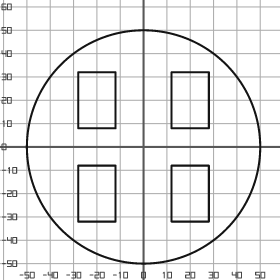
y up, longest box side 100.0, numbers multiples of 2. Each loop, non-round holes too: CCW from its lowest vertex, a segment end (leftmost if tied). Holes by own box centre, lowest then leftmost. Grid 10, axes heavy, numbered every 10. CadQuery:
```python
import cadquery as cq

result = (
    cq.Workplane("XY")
    .moveTo(0.0, 0.0)
    .circle(50.0)
    .moveTo(-28.0, -32.0)
    .lineTo(-12.0, -32.0)
    .lineTo(-12.0, -8.0)
    .lineTo(-28.0, -8.0)
    .close()
    .moveTo(12.0, -32.0)
    .lineTo(28.0, -32.0)
    .lineTo(28.0, -8.0)
    .lineTo(12.0, -8.0)
    .close()
    .moveTo(-28.0, 8.0)
    .lineTo(-12.0, 8.0)
    .lineTo(-12.0, 32.0)
    .lineTo(-28.0, 32.0)
    .close()
    .moveTo(12.0, 8.0)
    .lineTo(28.0, 8.0)
    .lineTo(28.0, 32.0)
    .lineTo(12.0, 32.0)
    .close()
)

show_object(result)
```